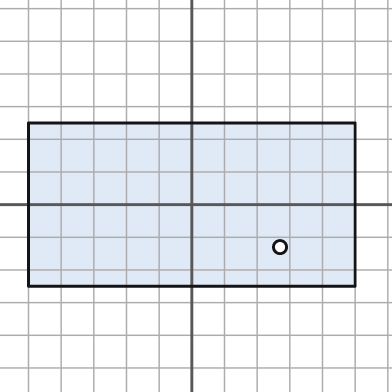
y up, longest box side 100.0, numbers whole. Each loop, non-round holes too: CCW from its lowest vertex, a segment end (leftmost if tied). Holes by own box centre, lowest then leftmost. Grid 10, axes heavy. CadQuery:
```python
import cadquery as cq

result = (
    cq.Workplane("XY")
    .moveTo(-50.0, -25.0)
    .lineTo(50.0, -25.0)
    .lineTo(50.0, 25.0)
    .lineTo(-50.0, 25.0)
    .close()
    .moveTo(27.0, -13.0)
    .circle(2.0)
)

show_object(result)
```